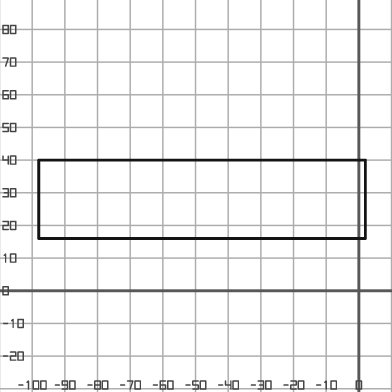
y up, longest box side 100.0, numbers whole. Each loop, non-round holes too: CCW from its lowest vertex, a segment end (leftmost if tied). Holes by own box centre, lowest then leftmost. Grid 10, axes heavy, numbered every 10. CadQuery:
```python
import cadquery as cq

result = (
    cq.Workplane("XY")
    .moveTo(-98.0, 16.0)
    .lineTo(2.0, 16.0)
    .lineTo(2.0, 40.0)
    .lineTo(-98.0, 40.0)
    .close()
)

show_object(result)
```